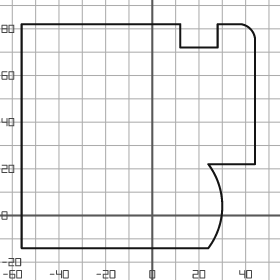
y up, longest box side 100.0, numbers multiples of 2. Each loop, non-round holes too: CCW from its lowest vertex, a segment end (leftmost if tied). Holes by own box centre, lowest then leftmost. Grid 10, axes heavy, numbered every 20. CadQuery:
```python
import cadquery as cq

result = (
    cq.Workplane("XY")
    .moveTo(-56.0, -14.0)
    .lineTo(24.0, -14.0)
    .threePointArc((30.0, 4.0), (24.0, 22.0))
    .lineTo(44.0, 22.0)
    .lineTo(44.0, 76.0)
    .threePointArc((42.0, 80.0), (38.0, 82.0))
    .lineTo(28.0, 82.0)
    .lineTo(28.0, 72.0)
    .lineTo(12.0, 72.0)
    .lineTo(12.0, 82.0)
    .lineTo(-56.0, 82.0)
    .close()
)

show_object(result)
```